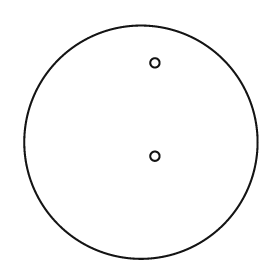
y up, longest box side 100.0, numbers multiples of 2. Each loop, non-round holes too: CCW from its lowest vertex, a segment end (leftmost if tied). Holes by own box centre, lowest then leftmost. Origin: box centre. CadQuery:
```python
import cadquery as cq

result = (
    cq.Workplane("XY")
    .moveTo(0.0, 0.0)
    .circle(50.0)
    .moveTo(6.0, -6.0)
    .circle(2.0)
    .moveTo(6.0, 34.0)
    .circle(2.0)
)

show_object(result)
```